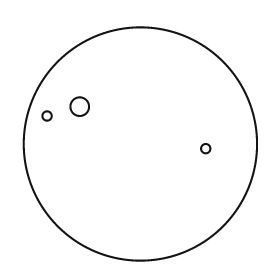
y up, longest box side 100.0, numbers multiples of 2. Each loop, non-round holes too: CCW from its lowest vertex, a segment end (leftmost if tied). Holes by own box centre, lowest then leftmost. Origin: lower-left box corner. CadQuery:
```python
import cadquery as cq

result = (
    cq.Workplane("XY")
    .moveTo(50.0, 50.0)
    .circle(50.0)
    .moveTo(78.0, 48.0)
    .circle(2.0)
    .moveTo(10.0, 62.0)
    .circle(2.0)
    .moveTo(24.0, 66.0)
    .circle(4.0)
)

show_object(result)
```